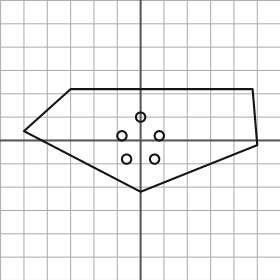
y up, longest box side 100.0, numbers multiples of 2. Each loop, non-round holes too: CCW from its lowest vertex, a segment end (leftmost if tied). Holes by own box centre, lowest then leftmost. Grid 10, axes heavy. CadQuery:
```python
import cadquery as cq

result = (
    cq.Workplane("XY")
    .moveTo(0.0, -22.0)
    .lineTo(50.0, -2.0)
    .lineTo(48.0, 22.0)
    .lineTo(-30.0, 22.0)
    .lineTo(-50.0, 4.0)
    .close()
    .moveTo(-6.0, -8.0)
    .circle(2.0)
    .moveTo(6.0, -8.0)
    .circle(2.0)
    .moveTo(-8.0, 2.0)
    .circle(2.0)
    .moveTo(8.0, 2.0)
    .circle(2.0)
    .moveTo(0.0, 10.0)
    .circle(2.0)
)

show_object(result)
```